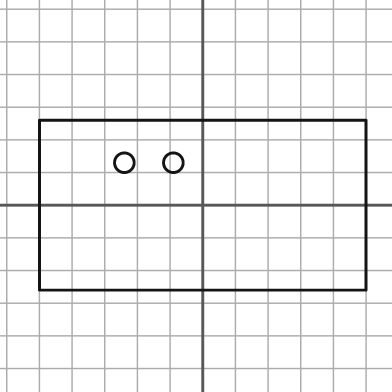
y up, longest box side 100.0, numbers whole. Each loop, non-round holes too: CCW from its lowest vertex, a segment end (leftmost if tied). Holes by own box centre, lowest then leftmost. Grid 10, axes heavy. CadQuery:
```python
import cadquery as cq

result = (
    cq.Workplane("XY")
    .moveTo(-50.0, -26.0)
    .lineTo(50.0, -26.0)
    .lineTo(50.0, 26.0)
    .lineTo(-50.0, 26.0)
    .close()
    .moveTo(-24.0, 13.0)
    .circle(3.0)
    .moveTo(-9.0, 13.0)
    .circle(3.0)
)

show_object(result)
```